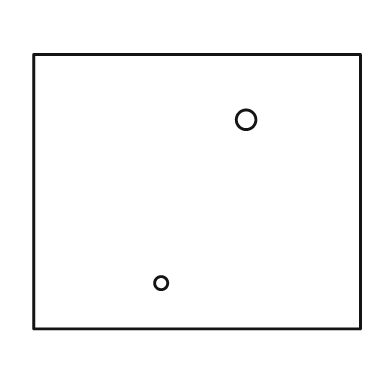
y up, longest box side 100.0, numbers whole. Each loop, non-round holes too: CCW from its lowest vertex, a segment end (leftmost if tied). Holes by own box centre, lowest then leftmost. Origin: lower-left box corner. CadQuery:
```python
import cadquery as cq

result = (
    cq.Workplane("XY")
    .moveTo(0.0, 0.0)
    .lineTo(100.0, 0.0)
    .lineTo(100.0, 84.0)
    .lineTo(0.0, 84.0)
    .close()
    .moveTo(39.0, 14.0)
    .circle(2.0)
    .moveTo(65.0, 64.0)
    .circle(3.0)
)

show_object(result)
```